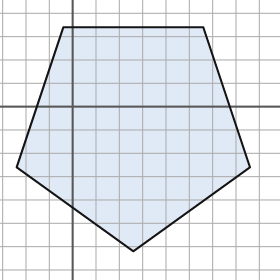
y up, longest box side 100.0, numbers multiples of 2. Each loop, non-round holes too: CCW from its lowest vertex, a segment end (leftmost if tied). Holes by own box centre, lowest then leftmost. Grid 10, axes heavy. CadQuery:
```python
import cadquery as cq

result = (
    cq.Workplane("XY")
    .moveTo(26.0, -62.0)
    .lineTo(76.0, -26.0)
    .lineTo(56.0, 34.0)
    .lineTo(-4.0, 34.0)
    .lineTo(-24.0, -26.0)
    .close()
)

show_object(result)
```